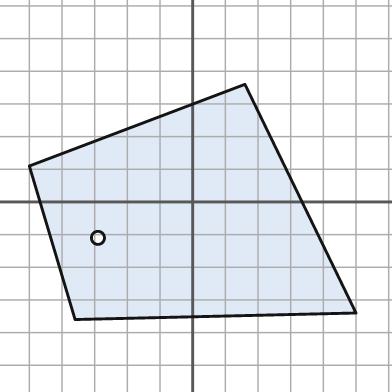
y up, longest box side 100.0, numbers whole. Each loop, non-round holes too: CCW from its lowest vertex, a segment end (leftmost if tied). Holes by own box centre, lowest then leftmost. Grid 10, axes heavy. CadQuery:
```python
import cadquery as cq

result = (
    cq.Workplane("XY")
    .moveTo(-36.0, -36.0)
    .lineTo(50.0, -34.0)
    .lineTo(16.0, 36.0)
    .lineTo(-50.0, 11.0)
    .close()
    .moveTo(-29.0, -11.0)
    .circle(2.0)
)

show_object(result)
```